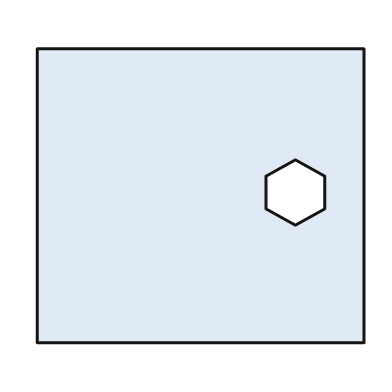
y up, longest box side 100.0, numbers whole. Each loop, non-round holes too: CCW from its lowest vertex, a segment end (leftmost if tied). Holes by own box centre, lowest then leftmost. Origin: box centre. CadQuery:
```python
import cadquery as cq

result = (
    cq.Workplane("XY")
    .moveTo(-50.0, -45.0)
    .lineTo(50.0, -45.0)
    .lineTo(50.0, 45.0)
    .lineTo(-50.0, 45.0)
    .close()
    .moveTo(29.0, -9.0)
    .lineTo(38.0, -4.0)
    .lineTo(38.0, 6.0)
    .lineTo(29.0, 11.0)
    .lineTo(20.0, 6.0)
    .lineTo(20.0, -4.0)
    .close()
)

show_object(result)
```